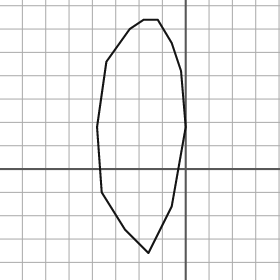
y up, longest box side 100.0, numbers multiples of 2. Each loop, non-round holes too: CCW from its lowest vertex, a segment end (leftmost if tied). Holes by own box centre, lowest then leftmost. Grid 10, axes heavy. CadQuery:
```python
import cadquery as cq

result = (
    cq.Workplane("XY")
    .moveTo(-16.0, -36.0)
    .lineTo(-6.0, -16.0)
    .lineTo(0.0, 18.0)
    .lineTo(-2.0, 42.0)
    .lineTo(-6.0, 54.0)
    .lineTo(-12.0, 64.0)
    .lineTo(-18.0, 64.0)
    .lineTo(-24.0, 60.0)
    .lineTo(-34.0, 46.0)
    .lineTo(-38.0, 18.0)
    .lineTo(-36.0, -10.0)
    .lineTo(-26.0, -26.0)
    .close()
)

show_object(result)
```